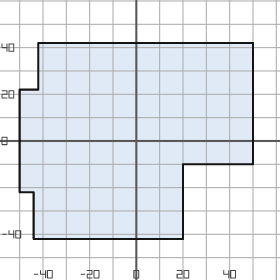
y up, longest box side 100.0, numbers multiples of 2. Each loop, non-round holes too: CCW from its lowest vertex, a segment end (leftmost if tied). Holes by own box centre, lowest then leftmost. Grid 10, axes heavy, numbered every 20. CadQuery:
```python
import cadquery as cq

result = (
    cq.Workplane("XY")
    .moveTo(-44.0, -42.0)
    .lineTo(20.0, -42.0)
    .lineTo(20.0, -10.0)
    .lineTo(50.0, -10.0)
    .lineTo(50.0, 42.0)
    .lineTo(-42.0, 42.0)
    .lineTo(-42.0, 22.0)
    .lineTo(-50.0, 22.0)
    .lineTo(-50.0, -22.0)
    .lineTo(-44.0, -22.0)
    .close()
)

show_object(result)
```